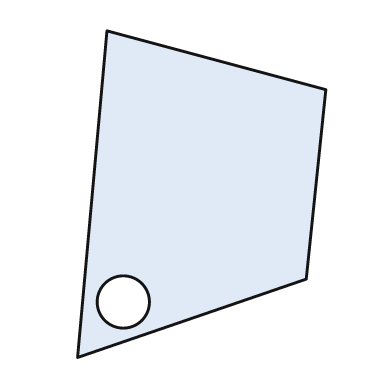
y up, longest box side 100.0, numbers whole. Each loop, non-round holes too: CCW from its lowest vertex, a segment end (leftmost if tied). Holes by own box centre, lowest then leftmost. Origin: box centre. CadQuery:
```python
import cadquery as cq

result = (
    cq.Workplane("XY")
    .moveTo(-38.0, -50.0)
    .lineTo(32.0, -26.0)
    .lineTo(38.0, 32.0)
    .lineTo(-29.0, 50.0)
    .close()
    .moveTo(-24.0, -33.0)
    .circle(8.0)
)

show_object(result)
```